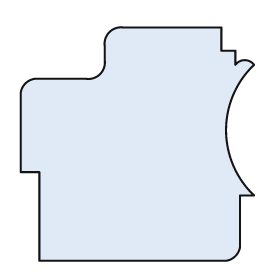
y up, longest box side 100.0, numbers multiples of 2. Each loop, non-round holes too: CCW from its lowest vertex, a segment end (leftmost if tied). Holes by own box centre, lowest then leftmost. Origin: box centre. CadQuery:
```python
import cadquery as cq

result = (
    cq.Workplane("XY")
    .moveTo(-42.0, -50.0)
    .lineTo(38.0, -50.0)
    .threePointArc((42.0, -48.0), (44.0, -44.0))
    .lineTo(44.0, -22.0)
    .lineTo(50.0, -22.0)
    .threePointArc((38.0, 6.0), (50.0, 34.0))
    .threePointArc((46.0, 36.0), (42.0, 34.0))
    .lineTo(42.0, 40.0)
    .lineTo(36.0, 40.0)
    .lineTo(36.0, 50.0)
    .lineTo(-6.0, 50.0)
    .threePointArc((-12.0, 48.0), (-14.0, 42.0))
    .lineTo(-14.0, 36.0)
    .threePointArc((-16.0, 30.0), (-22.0, 28.0))
    .lineTo(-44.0, 28.0)
    .threePointArc((-48.0, 26.0), (-50.0, 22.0))
    .lineTo(-50.0, -12.0)
    .lineTo(-42.0, -12.0)
    .close()
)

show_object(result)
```